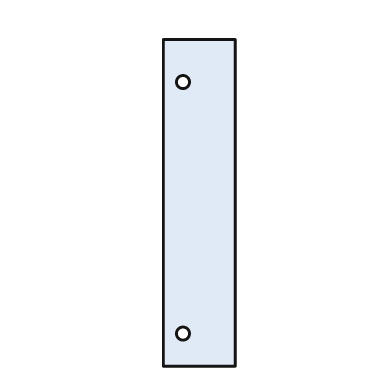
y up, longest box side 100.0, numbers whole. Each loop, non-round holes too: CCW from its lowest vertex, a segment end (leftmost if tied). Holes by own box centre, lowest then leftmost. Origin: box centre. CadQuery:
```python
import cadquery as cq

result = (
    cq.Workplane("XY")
    .moveTo(-11.0, -50.0)
    .lineTo(11.0, -50.0)
    .lineTo(11.0, 50.0)
    .lineTo(-11.0, 50.0)
    .close()
    .moveTo(-5.0, -40.0)
    .circle(2.0)
    .moveTo(-5.0, 37.0)
    .circle(2.0)
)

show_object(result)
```